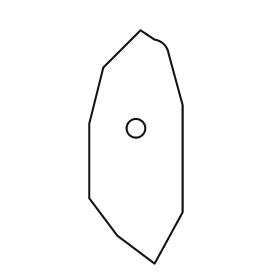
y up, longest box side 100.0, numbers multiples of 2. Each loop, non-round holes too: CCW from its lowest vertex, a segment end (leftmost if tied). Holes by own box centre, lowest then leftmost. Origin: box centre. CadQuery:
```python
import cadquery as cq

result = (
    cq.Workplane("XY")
    .moveTo(8.0, -50.0)
    .lineTo(20.0, -28.0)
    .lineTo(20.0, 18.0)
    .lineTo(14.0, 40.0)
    .threePointArc((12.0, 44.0), (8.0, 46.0))
    .lineTo(2.0, 50.0)
    .lineTo(-14.0, 34.0)
    .lineTo(-20.0, 10.0)
    .lineTo(-20.0, -22.0)
    .lineTo(-8.0, -38.0)
    .close()
    .moveTo(0.0, 8.0)
    .circle(4.0)
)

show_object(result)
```